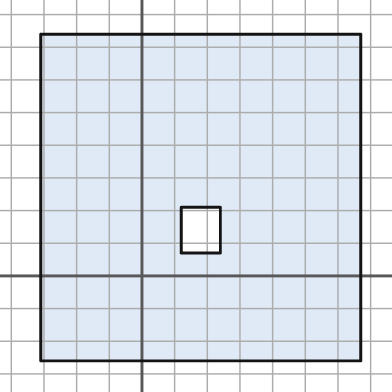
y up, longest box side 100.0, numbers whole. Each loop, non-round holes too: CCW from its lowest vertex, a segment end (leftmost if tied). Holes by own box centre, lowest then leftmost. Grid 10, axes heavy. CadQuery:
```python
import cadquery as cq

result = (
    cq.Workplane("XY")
    .moveTo(-31.0, -26.0)
    .lineTo(67.0, -26.0)
    .lineTo(67.0, 74.0)
    .lineTo(-31.0, 74.0)
    .close()
    .moveTo(12.0, 7.0)
    .lineTo(24.0, 7.0)
    .lineTo(24.0, 21.0)
    .lineTo(12.0, 21.0)
    .close()
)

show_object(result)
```